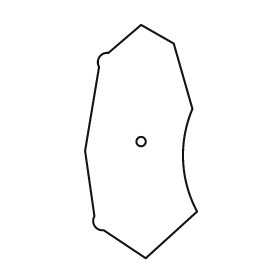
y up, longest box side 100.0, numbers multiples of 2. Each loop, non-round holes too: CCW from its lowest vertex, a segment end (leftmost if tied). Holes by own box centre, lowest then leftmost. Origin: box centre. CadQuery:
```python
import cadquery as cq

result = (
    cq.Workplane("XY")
    .moveTo(2.0, -50.0)
    .lineTo(24.0, -30.0)
    .threePointArc((18.0, -8.0), (22.0, 14.0))
    .lineTo(14.0, 42.0)
    .lineTo(0.0, 50.0)
    .lineTo(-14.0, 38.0)
    .threePointArc((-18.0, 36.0), (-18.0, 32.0))
    .lineTo(-24.0, -4.0)
    .lineTo(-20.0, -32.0)
    .threePointArc((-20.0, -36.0), (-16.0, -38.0))
    .close()
    .moveTo(0.0, 0.0)
    .circle(2.0)
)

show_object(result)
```